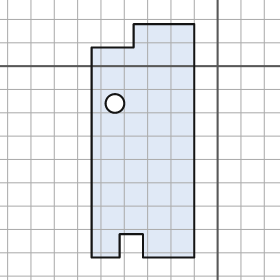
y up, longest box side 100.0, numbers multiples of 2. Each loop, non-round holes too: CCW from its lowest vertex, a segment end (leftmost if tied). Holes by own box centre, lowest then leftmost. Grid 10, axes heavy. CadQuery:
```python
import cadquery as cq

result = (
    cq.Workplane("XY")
    .moveTo(-54.0, -82.0)
    .lineTo(-42.0, -82.0)
    .lineTo(-42.0, -72.0)
    .lineTo(-32.0, -72.0)
    .lineTo(-32.0, -82.0)
    .lineTo(-10.0, -82.0)
    .lineTo(-10.0, 18.0)
    .lineTo(-36.0, 18.0)
    .lineTo(-36.0, 8.0)
    .lineTo(-54.0, 8.0)
    .close()
    .moveTo(-44.0, -16.0)
    .circle(4.0)
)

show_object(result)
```